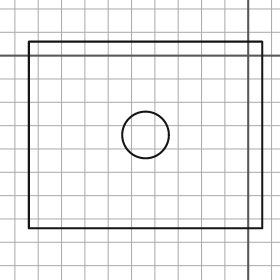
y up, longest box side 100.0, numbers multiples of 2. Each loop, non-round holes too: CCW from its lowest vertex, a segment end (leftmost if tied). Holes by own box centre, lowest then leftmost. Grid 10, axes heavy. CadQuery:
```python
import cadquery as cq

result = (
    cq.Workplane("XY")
    .moveTo(-94.0, -74.0)
    .lineTo(6.0, -74.0)
    .lineTo(6.0, 6.0)
    .lineTo(-94.0, 6.0)
    .close()
    .moveTo(-44.0, -34.0)
    .circle(10.0)
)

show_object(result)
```